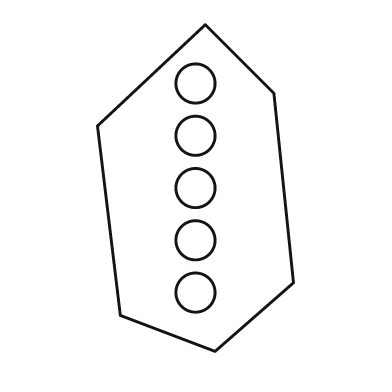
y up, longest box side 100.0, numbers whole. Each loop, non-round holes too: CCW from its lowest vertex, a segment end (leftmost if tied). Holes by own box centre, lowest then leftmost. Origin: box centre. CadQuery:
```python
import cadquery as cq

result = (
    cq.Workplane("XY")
    .moveTo(6.0, -50.0)
    .lineTo(30.0, -29.0)
    .lineTo(24.0, 29.0)
    .lineTo(3.0, 50.0)
    .lineTo(-30.0, 19.0)
    .lineTo(-23.0, -39.0)
    .close()
    .moveTo(0.0, -32.0)
    .circle(6.0)
    .moveTo(0.0, -16.0)
    .circle(6.0)
    .moveTo(0.0, 0.0)
    .circle(6.0)
    .moveTo(0.0, 16.0)
    .circle(6.0)
    .moveTo(0.0, 32.0)
    .circle(6.0)
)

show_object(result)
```